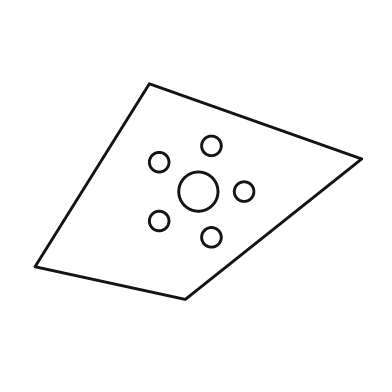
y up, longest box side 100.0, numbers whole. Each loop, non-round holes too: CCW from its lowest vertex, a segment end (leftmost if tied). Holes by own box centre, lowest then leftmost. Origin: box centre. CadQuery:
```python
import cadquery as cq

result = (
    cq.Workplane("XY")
    .moveTo(-4.0, -33.0)
    .lineTo(50.0, 10.0)
    .lineTo(-15.0, 33.0)
    .lineTo(-50.0, -23.0)
    .close()
    .moveTo(4.0, -14.0)
    .circle(3.0)
    .moveTo(-12.0, -9.0)
    .circle(3.0)
    .moveTo(0.0, 0.0)
    .circle(6.0)
    .moveTo(14.0, 0.0)
    .circle(3.0)
    .moveTo(-12.0, 9.0)
    .circle(3.0)
    .moveTo(4.0, 14.0)
    .circle(3.0)
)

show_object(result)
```